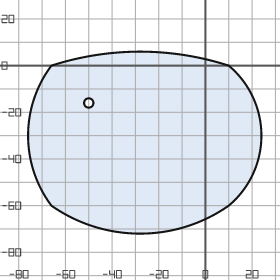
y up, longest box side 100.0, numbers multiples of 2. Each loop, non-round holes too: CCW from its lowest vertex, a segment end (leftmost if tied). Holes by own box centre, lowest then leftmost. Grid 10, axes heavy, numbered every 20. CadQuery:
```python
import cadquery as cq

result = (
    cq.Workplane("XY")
    .moveTo(-66.0, -60.0)
    .threePointArc((-28.0, -72.0), (10.0, -60.0))
    .threePointArc((24.0, -30.0), (10.0, 0.0))
    .threePointArc((-28.0, 6.0), (-66.0, 0.0))
    .threePointArc((-76.0, -30.0), (-66.0, -60.0))
    .close()
    .moveTo(-50.0, -16.0)
    .circle(2.0)
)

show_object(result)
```